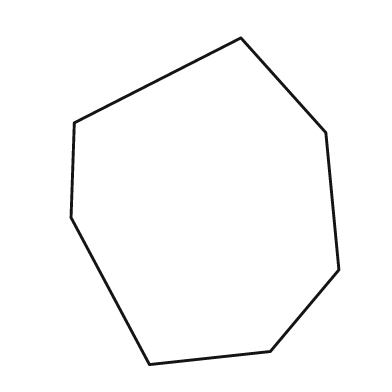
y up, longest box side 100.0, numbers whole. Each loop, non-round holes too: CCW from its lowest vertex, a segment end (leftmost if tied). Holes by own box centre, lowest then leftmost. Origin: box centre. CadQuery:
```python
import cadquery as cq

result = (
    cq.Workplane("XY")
    .moveTo(-17.0, -50.0)
    .lineTo(20.0, -46.0)
    .lineTo(41.0, -21.0)
    .lineTo(37.0, 21.0)
    .lineTo(11.0, 50.0)
    .lineTo(-40.0, 24.0)
    .lineTo(-41.0, -5.0)
    .close()
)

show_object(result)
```